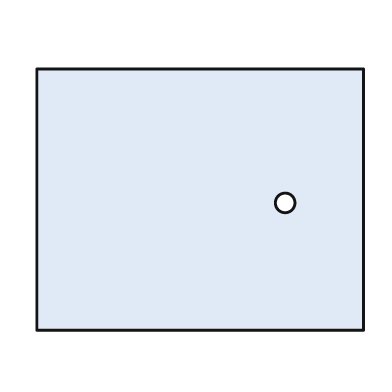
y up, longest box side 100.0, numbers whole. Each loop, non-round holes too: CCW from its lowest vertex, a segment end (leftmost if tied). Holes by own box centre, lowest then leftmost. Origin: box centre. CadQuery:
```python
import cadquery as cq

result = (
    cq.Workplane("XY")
    .moveTo(-50.0, -40.0)
    .lineTo(50.0, -40.0)
    .lineTo(50.0, 40.0)
    .lineTo(-50.0, 40.0)
    .close()
    .moveTo(26.0, -1.0)
    .circle(3.0)
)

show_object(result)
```